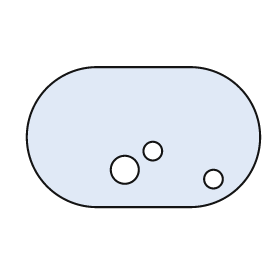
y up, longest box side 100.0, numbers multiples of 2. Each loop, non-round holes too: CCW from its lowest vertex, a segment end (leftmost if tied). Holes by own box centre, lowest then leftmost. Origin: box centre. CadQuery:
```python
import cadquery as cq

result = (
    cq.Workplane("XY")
    .moveTo(-20.0, -30.0)
    .lineTo(20.0, -30.0)
    .threePointArc((50.0, 0.0), (20.0, 30.0))
    .lineTo(-20.0, 30.0)
    .threePointArc((-50.0, 0.0), (-20.0, -30.0))
    .close()
    .moveTo(30.0, -18.0)
    .circle(4.0)
    .moveTo(-8.0, -14.0)
    .circle(6.0)
    .moveTo(4.0, -6.0)
    .circle(4.0)
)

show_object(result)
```